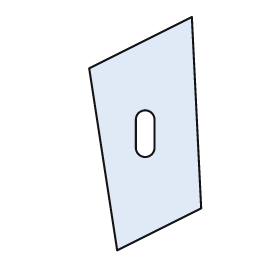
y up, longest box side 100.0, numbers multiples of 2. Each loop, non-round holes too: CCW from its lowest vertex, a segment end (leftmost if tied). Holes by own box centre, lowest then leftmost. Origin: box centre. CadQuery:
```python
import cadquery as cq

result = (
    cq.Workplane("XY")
    .moveTo(-12.0, -50.0)
    .lineTo(24.0, -32.0)
    .lineTo(20.0, 50.0)
    .lineTo(-24.0, 28.0)
    .close()
    .moveTo(-4.0, -6.0)
    .threePointArc((0.0, -10.0), (4.0, -6.0))
    .lineTo(4.0, 6.0)
    .threePointArc((0.0, 10.0), (-4.0, 6.0))
    .close()
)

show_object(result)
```